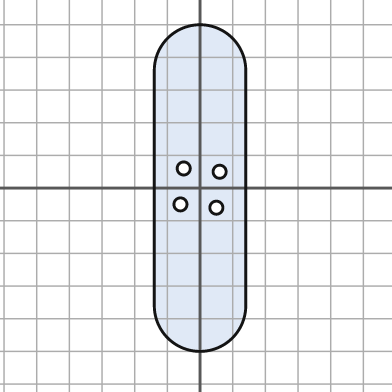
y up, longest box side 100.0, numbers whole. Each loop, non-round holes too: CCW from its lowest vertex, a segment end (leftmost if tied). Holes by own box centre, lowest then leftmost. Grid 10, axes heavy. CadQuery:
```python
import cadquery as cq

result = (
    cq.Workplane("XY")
    .moveTo(-14.0, -36.0)
    .threePointArc((0.0, -50.0), (14.0, -36.0))
    .lineTo(14.0, 36.0)
    .threePointArc((0.0, 50.0), (-14.0, 36.0))
    .close()
    .moveTo(5.0, -6.0)
    .circle(2.0)
    .moveTo(-6.0, -5.0)
    .circle(2.0)
    .moveTo(6.0, 5.0)
    .circle(2.0)
    .moveTo(-5.0, 6.0)
    .circle(2.0)
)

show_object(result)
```